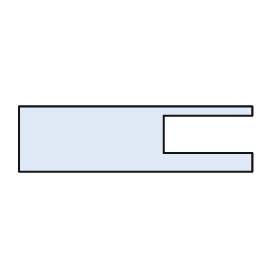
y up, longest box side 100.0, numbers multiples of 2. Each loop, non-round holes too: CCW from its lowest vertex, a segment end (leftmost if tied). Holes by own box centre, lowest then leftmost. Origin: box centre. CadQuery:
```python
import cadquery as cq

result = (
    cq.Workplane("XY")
    .moveTo(-50.0, -14.0)
    .lineTo(50.0, -14.0)
    .lineTo(50.0, -6.0)
    .lineTo(12.0, -6.0)
    .lineTo(12.0, 10.0)
    .lineTo(50.0, 10.0)
    .lineTo(50.0, 14.0)
    .lineTo(-50.0, 14.0)
    .close()
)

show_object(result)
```